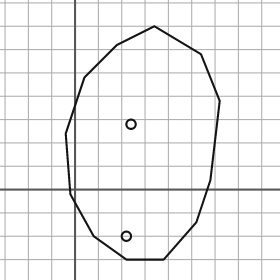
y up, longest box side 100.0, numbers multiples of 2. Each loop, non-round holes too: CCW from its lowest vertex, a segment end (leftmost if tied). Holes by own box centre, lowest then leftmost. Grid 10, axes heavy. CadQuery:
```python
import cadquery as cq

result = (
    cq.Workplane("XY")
    .moveTo(22.0, -30.0)
    .lineTo(38.0, -30.0)
    .lineTo(52.0, -14.0)
    .lineTo(58.0, 4.0)
    .lineTo(62.0, 38.0)
    .lineTo(54.0, 58.0)
    .lineTo(34.0, 70.0)
    .lineTo(18.0, 62.0)
    .lineTo(4.0, 48.0)
    .lineTo(-4.0, 24.0)
    .lineTo(-2.0, -2.0)
    .lineTo(8.0, -20.0)
    .close()
    .moveTo(22.0, -20.0)
    .circle(2.0)
    .moveTo(24.0, 28.0)
    .circle(2.0)
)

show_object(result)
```